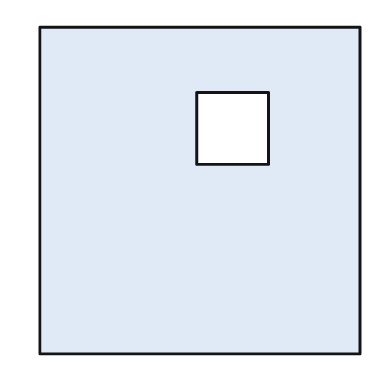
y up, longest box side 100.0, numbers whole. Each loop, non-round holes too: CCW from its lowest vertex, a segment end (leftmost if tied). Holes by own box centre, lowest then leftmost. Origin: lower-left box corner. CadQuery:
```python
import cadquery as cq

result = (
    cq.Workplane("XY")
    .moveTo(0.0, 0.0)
    .lineTo(98.0, 0.0)
    .lineTo(98.0, 100.0)
    .lineTo(0.0, 100.0)
    .close()
    .moveTo(48.0, 58.0)
    .lineTo(70.0, 58.0)
    .lineTo(70.0, 80.0)
    .lineTo(48.0, 80.0)
    .close()
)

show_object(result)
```